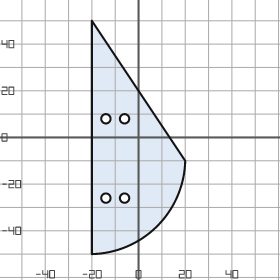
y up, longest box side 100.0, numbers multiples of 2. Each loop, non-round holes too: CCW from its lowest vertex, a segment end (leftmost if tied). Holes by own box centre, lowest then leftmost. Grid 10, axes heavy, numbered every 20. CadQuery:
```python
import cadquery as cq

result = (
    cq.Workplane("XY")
    .moveTo(-20.0, -50.0)
    .threePointArc((8.0, -38.0), (20.0, -10.0))
    .lineTo(-20.0, 50.0)
    .close()
    .moveTo(-14.0, -26.0)
    .circle(2.0)
    .moveTo(-6.0, -26.0)
    .circle(2.0)
    .moveTo(-14.0, 8.0)
    .circle(2.0)
    .moveTo(-6.0, 8.0)
    .circle(2.0)
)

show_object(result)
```